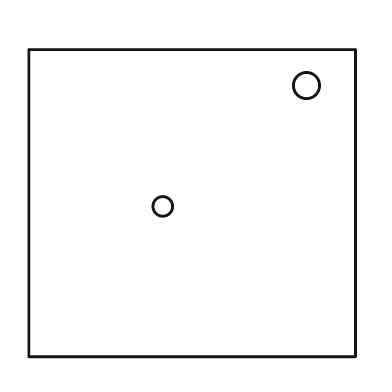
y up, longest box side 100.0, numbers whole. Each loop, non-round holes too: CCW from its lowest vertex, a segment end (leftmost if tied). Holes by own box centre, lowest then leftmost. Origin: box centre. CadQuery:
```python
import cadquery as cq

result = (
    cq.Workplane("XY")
    .moveTo(-50.0, -47.0)
    .lineTo(50.0, -47.0)
    .lineTo(50.0, 47.0)
    .lineTo(-50.0, 47.0)
    .close()
    .moveTo(-9.0, -1.0)
    .circle(3.0)
    .moveTo(35.0, 36.0)
    .circle(4.0)
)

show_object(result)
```